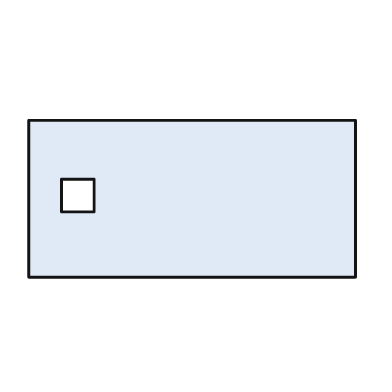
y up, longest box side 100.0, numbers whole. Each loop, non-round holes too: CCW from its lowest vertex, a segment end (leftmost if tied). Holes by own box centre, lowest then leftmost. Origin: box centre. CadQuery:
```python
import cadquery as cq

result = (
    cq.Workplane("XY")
    .moveTo(-50.0, -24.0)
    .lineTo(50.0, -24.0)
    .lineTo(50.0, 24.0)
    .lineTo(-50.0, 24.0)
    .close()
    .moveTo(-40.0, -4.0)
    .lineTo(-30.0, -4.0)
    .lineTo(-30.0, 6.0)
    .lineTo(-40.0, 6.0)
    .close()
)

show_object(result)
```